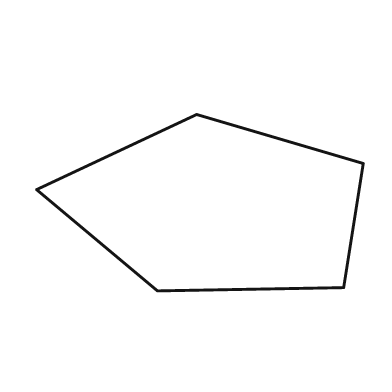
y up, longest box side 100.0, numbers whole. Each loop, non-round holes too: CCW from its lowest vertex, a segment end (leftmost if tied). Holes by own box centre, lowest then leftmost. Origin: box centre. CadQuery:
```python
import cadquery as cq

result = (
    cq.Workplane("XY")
    .moveTo(-13.0, -27.0)
    .lineTo(44.0, -26.0)
    .lineTo(50.0, 12.0)
    .lineTo(-1.0, 27.0)
    .lineTo(-50.0, 4.0)
    .close()
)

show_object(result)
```